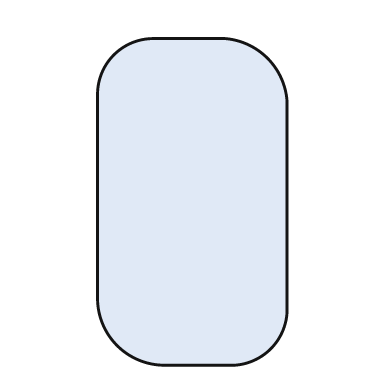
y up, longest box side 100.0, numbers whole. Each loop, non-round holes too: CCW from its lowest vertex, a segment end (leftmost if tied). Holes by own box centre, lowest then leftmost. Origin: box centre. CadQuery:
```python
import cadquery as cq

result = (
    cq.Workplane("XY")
    .moveTo(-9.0, -50.0)
    .lineTo(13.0, -50.0)
    .threePointArc((24.0, -45.0), (29.0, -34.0))
    .lineTo(29.0, 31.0)
    .threePointArc((23.0, 44.0), (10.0, 50.0))
    .lineTo(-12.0, 50.0)
    .threePointArc((-24.0, 45.0), (-29.0, 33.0))
    .lineTo(-29.0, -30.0)
    .threePointArc((-23.0, -44.0), (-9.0, -50.0))
    .close()
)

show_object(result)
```